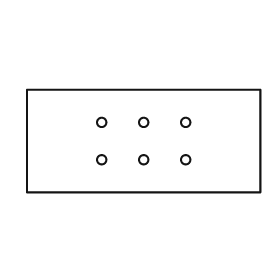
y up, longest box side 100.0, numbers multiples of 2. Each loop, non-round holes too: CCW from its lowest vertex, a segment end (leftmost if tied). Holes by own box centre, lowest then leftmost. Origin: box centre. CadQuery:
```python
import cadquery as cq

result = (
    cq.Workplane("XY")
    .moveTo(-50.0, -22.0)
    .lineTo(50.0, -22.0)
    .lineTo(50.0, 22.0)
    .lineTo(-50.0, 22.0)
    .close()
    .moveTo(-18.0, -8.0)
    .circle(2.0)
    .moveTo(0.0, -8.0)
    .circle(2.0)
    .moveTo(18.0, -8.0)
    .circle(2.0)
    .moveTo(-18.0, 8.0)
    .circle(2.0)
    .moveTo(0.0, 8.0)
    .circle(2.0)
    .moveTo(18.0, 8.0)
    .circle(2.0)
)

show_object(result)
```